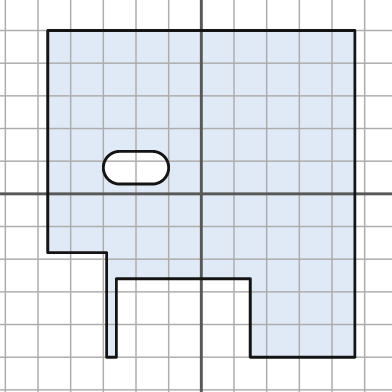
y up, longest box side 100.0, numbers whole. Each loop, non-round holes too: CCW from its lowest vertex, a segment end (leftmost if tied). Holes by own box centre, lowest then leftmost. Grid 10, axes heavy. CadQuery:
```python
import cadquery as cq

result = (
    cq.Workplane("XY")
    .moveTo(-29.0, -50.0)
    .lineTo(-26.0, -50.0)
    .lineTo(-26.0, -26.0)
    .lineTo(15.0, -26.0)
    .lineTo(15.0, -50.0)
    .lineTo(47.0, -50.0)
    .lineTo(47.0, 50.0)
    .lineTo(-47.0, 50.0)
    .lineTo(-47.0, -18.0)
    .lineTo(-29.0, -18.0)
    .close()
    .moveTo(-25.0, 3.0)
    .lineTo(-15.0, 3.0)
    .threePointArc((-10.0, 8.0), (-15.0, 13.0))
    .lineTo(-25.0, 13.0)
    .threePointArc((-30.0, 8.0), (-25.0, 3.0))
    .close()
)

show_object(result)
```